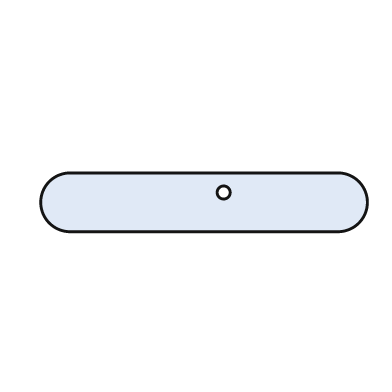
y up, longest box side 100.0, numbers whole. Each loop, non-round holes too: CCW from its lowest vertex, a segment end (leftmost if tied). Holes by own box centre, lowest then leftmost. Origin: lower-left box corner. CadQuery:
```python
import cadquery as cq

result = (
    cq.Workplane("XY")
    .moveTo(9.0, 0.0)
    .lineTo(91.0, 0.0)
    .threePointArc((100.0, 9.0), (91.0, 18.0))
    .lineTo(9.0, 18.0)
    .threePointArc((0.0, 9.0), (9.0, 0.0))
    .close()
    .moveTo(56.0, 12.0)
    .circle(2.0)
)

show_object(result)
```